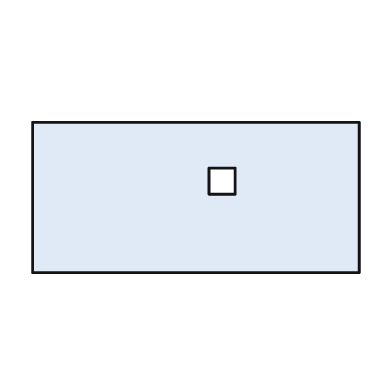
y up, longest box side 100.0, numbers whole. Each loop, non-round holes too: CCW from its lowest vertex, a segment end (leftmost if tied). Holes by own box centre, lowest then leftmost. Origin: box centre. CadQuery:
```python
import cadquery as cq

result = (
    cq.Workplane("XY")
    .moveTo(-50.0, -23.0)
    .lineTo(50.0, -23.0)
    .lineTo(50.0, 23.0)
    .lineTo(-50.0, 23.0)
    .close()
    .moveTo(4.0, 1.0)
    .lineTo(12.0, 1.0)
    .lineTo(12.0, 9.0)
    .lineTo(4.0, 9.0)
    .close()
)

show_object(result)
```